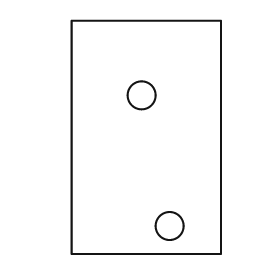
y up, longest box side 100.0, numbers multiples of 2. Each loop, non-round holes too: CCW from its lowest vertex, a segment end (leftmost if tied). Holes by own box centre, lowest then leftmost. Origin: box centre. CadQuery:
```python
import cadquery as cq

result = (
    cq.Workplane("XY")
    .moveTo(-32.0, -50.0)
    .lineTo(32.0, -50.0)
    .lineTo(32.0, 50.0)
    .lineTo(-32.0, 50.0)
    .close()
    .moveTo(10.0, -38.0)
    .circle(6.0)
    .moveTo(-2.0, 18.0)
    .circle(6.0)
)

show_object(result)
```